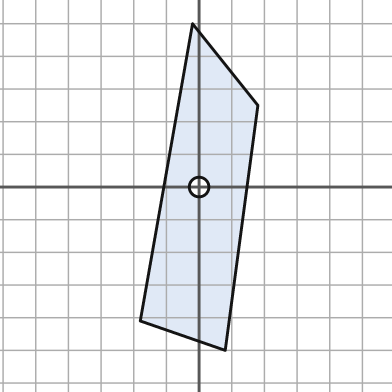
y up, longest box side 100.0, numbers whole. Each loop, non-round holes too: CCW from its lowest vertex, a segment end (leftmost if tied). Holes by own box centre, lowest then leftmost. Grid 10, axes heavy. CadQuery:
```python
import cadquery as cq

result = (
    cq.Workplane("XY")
    .moveTo(8.0, -50.0)
    .lineTo(18.0, 25.0)
    .lineTo(-2.0, 50.0)
    .lineTo(-18.0, -41.0)
    .close()
    .moveTo(0.0, 0.0)
    .circle(3.0)
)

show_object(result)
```